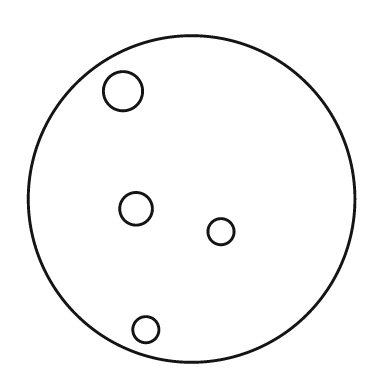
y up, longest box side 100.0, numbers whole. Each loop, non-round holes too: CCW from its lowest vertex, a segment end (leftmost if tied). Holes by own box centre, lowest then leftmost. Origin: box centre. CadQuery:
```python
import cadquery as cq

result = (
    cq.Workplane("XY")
    .moveTo(0.0, 0.0)
    .circle(50.0)
    .moveTo(-14.0, -40.0)
    .circle(4.0)
    .moveTo(9.0, -10.0)
    .circle(4.0)
    .moveTo(-17.0, -3.0)
    .circle(5.0)
    .moveTo(-21.0, 33.0)
    .circle(6.0)
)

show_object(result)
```